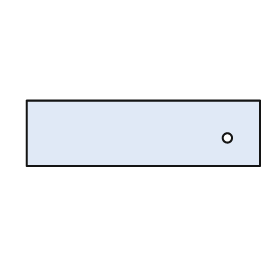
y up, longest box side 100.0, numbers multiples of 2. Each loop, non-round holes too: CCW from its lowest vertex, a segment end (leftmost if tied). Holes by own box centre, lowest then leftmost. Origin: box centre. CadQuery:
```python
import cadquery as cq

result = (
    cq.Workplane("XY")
    .moveTo(-50.0, -14.0)
    .lineTo(50.0, -14.0)
    .lineTo(50.0, 14.0)
    .lineTo(-50.0, 14.0)
    .close()
    .moveTo(36.0, -2.0)
    .circle(2.0)
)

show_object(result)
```